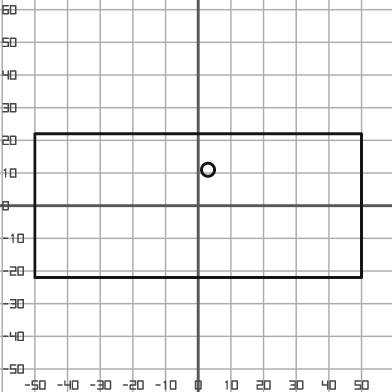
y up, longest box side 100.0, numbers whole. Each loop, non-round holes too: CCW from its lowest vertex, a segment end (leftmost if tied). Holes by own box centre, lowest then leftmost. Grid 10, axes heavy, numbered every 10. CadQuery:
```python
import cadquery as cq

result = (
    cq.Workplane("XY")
    .moveTo(-50.0, -22.0)
    .lineTo(50.0, -22.0)
    .lineTo(50.0, 22.0)
    .lineTo(-50.0, 22.0)
    .close()
    .moveTo(3.0, 11.0)
    .circle(2.0)
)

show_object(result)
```